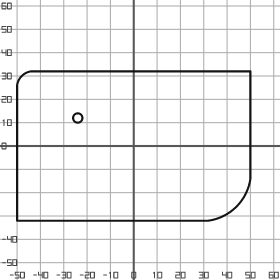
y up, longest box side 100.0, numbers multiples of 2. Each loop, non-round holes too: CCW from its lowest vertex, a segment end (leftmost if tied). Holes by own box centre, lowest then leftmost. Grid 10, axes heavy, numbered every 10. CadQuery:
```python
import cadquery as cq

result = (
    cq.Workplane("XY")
    .moveTo(-50.0, -32.0)
    .lineTo(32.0, -32.0)
    .threePointArc((44.0, -26.0), (50.0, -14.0))
    .lineTo(50.0, 32.0)
    .lineTo(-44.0, 32.0)
    .threePointArc((-48.0, 30.0), (-50.0, 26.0))
    .close()
    .moveTo(-24.0, 12.0)
    .circle(2.0)
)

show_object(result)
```